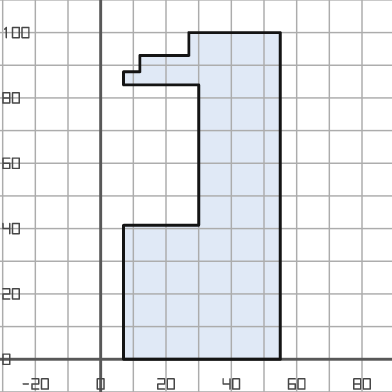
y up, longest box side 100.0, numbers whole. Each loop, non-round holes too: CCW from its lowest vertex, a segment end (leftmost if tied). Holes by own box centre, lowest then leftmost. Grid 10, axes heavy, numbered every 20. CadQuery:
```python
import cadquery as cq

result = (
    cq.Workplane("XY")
    .moveTo(7.0, 0.0)
    .lineTo(55.0, 0.0)
    .lineTo(55.0, 100.0)
    .lineTo(27.0, 100.0)
    .lineTo(27.0, 93.0)
    .lineTo(12.0, 93.0)
    .lineTo(12.0, 88.0)
    .lineTo(7.0, 88.0)
    .lineTo(7.0, 84.0)
    .lineTo(30.0, 84.0)
    .lineTo(30.0, 41.0)
    .lineTo(7.0, 41.0)
    .close()
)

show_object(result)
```